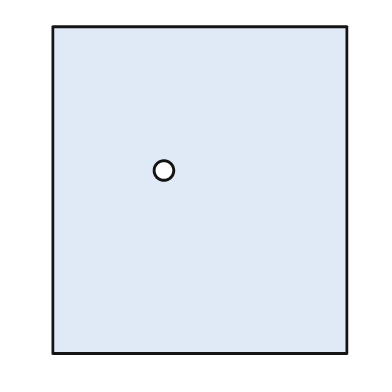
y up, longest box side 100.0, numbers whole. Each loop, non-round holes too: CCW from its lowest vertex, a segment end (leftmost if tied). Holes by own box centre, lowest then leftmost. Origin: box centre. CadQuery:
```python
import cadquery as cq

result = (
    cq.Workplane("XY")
    .moveTo(-45.0, -50.0)
    .lineTo(45.0, -50.0)
    .lineTo(45.0, 50.0)
    .lineTo(-45.0, 50.0)
    .close()
    .moveTo(-11.0, 6.0)
    .circle(3.0)
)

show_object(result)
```